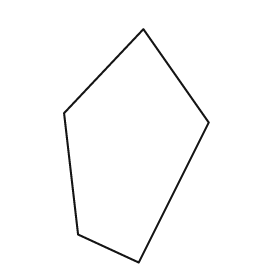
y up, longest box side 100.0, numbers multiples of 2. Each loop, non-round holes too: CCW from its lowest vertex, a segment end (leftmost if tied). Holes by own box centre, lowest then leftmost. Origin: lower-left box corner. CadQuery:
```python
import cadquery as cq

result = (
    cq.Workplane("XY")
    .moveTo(32.0, 0.0)
    .lineTo(62.0, 60.0)
    .lineTo(34.0, 100.0)
    .lineTo(0.0, 64.0)
    .lineTo(6.0, 12.0)
    .close()
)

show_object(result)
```